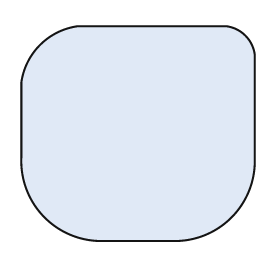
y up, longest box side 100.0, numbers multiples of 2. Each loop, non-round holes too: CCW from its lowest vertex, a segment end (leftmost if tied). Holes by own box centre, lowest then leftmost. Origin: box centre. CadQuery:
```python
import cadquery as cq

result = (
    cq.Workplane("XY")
    .moveTo(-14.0, -46.0)
    .lineTo(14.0, -46.0)
    .threePointArc((40.0, -36.0), (50.0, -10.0))
    .lineTo(50.0, 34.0)
    .threePointArc((46.0, 42.0), (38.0, 46.0))
    .lineTo(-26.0, 46.0)
    .threePointArc((-42.0, 38.0), (-50.0, 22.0))
    .lineTo(-50.0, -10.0)
    .threePointArc((-40.0, -36.0), (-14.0, -46.0))
    .close()
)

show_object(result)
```